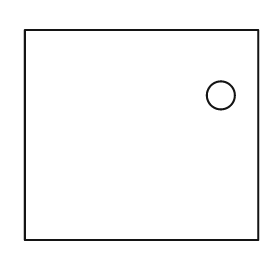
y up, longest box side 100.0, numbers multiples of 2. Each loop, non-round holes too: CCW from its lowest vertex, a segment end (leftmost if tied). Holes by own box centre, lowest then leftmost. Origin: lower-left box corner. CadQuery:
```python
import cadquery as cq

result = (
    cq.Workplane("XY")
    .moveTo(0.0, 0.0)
    .lineTo(100.0, 0.0)
    .lineTo(100.0, 90.0)
    .lineTo(0.0, 90.0)
    .close()
    .moveTo(84.0, 62.0)
    .circle(6.0)
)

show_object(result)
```